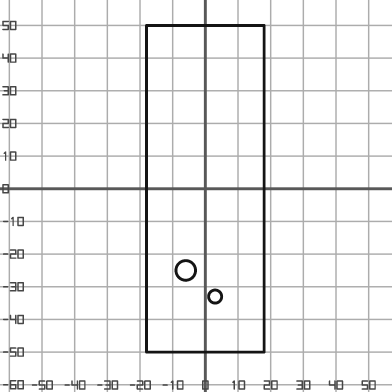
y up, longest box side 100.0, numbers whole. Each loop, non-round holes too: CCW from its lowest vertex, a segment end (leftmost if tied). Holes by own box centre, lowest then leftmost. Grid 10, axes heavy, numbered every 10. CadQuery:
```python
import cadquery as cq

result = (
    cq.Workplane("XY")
    .moveTo(-18.0, -50.0)
    .lineTo(18.0, -50.0)
    .lineTo(18.0, 50.0)
    .lineTo(-18.0, 50.0)
    .close()
    .moveTo(3.0, -33.0)
    .circle(2.0)
    .moveTo(-6.0, -25.0)
    .circle(3.0)
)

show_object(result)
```